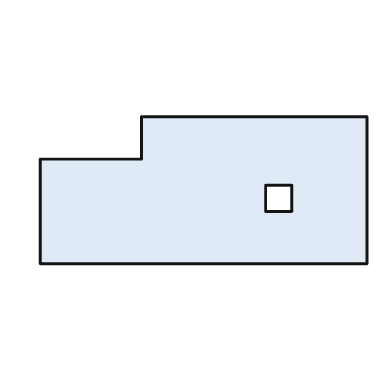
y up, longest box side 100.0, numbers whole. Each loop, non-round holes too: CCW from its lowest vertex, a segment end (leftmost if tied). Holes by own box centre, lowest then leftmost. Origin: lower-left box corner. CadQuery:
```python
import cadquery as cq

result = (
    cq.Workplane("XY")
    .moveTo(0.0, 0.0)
    .lineTo(100.0, 0.0)
    .lineTo(100.0, 45.0)
    .lineTo(31.0, 45.0)
    .lineTo(31.0, 32.0)
    .lineTo(0.0, 32.0)
    .close()
    .moveTo(69.0, 16.0)
    .lineTo(77.0, 16.0)
    .lineTo(77.0, 24.0)
    .lineTo(69.0, 24.0)
    .close()
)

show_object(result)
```